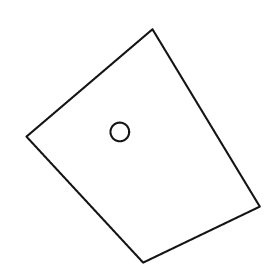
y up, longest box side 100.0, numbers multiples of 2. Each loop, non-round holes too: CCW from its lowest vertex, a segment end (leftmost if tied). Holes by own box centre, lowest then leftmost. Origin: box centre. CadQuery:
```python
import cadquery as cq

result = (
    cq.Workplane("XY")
    .moveTo(0.0, -50.0)
    .lineTo(50.0, -26.0)
    .lineTo(4.0, 50.0)
    .lineTo(-50.0, 4.0)
    .close()
    .moveTo(-10.0, 6.0)
    .circle(4.0)
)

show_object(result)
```